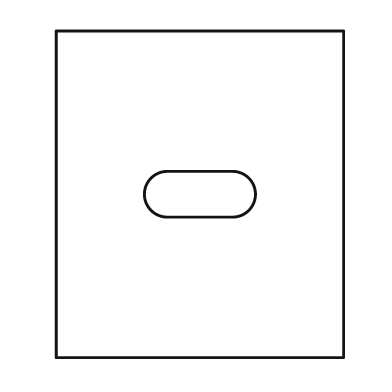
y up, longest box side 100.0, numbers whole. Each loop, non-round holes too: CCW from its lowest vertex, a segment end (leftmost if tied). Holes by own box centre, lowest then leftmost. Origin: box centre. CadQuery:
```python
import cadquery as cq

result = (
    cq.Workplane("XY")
    .moveTo(-44.0, -50.0)
    .lineTo(44.0, -50.0)
    .lineTo(44.0, 50.0)
    .lineTo(-44.0, 50.0)
    .close()
    .moveTo(-10.0, -7.0)
    .lineTo(10.0, -7.0)
    .threePointArc((17.0, 0.0), (10.0, 7.0))
    .lineTo(-10.0, 7.0)
    .threePointArc((-17.0, 0.0), (-10.0, -7.0))
    .close()
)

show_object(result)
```